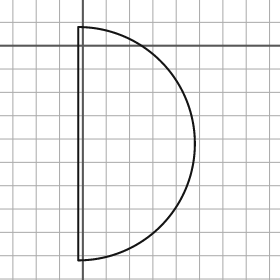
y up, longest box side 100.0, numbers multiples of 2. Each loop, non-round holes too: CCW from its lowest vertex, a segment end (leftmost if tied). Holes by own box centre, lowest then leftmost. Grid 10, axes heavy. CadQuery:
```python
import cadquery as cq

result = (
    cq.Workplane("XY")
    .moveTo(-2.0, -92.0)
    .threePointArc((48.0, -42.0), (-2.0, 8.0))
    .close()
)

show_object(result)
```